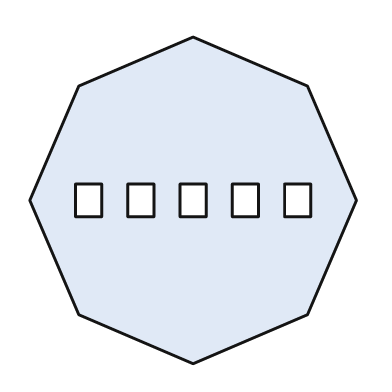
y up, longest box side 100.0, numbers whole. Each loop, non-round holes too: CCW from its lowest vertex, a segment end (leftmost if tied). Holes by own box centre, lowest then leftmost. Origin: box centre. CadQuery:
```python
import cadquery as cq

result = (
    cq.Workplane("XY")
    .moveTo(0.0, -50.0)
    .lineTo(35.0, -35.0)
    .lineTo(50.0, 0.0)
    .lineTo(35.0, 35.0)
    .lineTo(0.0, 50.0)
    .lineTo(-35.0, 35.0)
    .lineTo(-50.0, 0.0)
    .lineTo(-35.0, -35.0)
    .close()
    .moveTo(-36.0, -5.0)
    .lineTo(-28.0, -5.0)
    .lineTo(-28.0, 5.0)
    .lineTo(-36.0, 5.0)
    .close()
    .moveTo(-20.0, -5.0)
    .lineTo(-12.0, -5.0)
    .lineTo(-12.0, 5.0)
    .lineTo(-20.0, 5.0)
    .close()
    .moveTo(-4.0, -5.0)
    .lineTo(4.0, -5.0)
    .lineTo(4.0, 5.0)
    .lineTo(-4.0, 5.0)
    .close()
    .moveTo(12.0, -5.0)
    .lineTo(20.0, -5.0)
    .lineTo(20.0, 5.0)
    .lineTo(12.0, 5.0)
    .close()
    .moveTo(28.0, -5.0)
    .lineTo(36.0, -5.0)
    .lineTo(36.0, 5.0)
    .lineTo(28.0, 5.0)
    .close()
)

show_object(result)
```